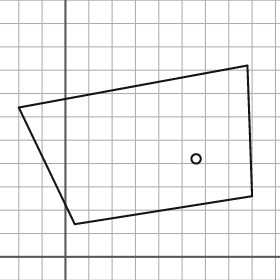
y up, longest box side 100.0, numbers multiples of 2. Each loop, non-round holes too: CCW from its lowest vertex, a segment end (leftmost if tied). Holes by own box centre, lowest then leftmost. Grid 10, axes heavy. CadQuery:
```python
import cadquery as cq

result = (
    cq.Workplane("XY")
    .moveTo(4.0, 14.0)
    .lineTo(80.0, 26.0)
    .lineTo(78.0, 82.0)
    .lineTo(-20.0, 64.0)
    .close()
    .moveTo(56.0, 42.0)
    .circle(2.0)
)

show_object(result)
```